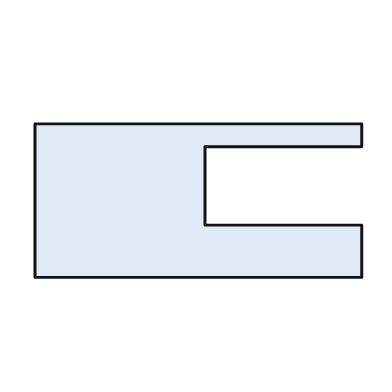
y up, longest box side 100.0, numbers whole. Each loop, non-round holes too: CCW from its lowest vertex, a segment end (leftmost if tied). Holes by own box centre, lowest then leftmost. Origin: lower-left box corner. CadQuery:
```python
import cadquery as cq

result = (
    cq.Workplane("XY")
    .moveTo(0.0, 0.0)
    .lineTo(100.0, 0.0)
    .lineTo(100.0, 16.0)
    .lineTo(52.0, 16.0)
    .lineTo(52.0, 40.0)
    .lineTo(100.0, 40.0)
    .lineTo(100.0, 47.0)
    .lineTo(0.0, 47.0)
    .close()
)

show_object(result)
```